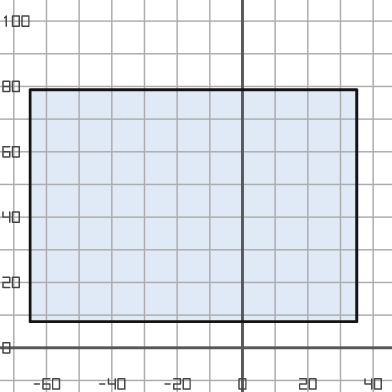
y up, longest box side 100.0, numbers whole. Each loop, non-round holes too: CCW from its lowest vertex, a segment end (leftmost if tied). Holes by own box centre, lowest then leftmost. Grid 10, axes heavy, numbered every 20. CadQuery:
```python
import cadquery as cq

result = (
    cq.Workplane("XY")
    .moveTo(-65.0, 8.0)
    .lineTo(35.0, 8.0)
    .lineTo(35.0, 79.0)
    .lineTo(-65.0, 79.0)
    .close()
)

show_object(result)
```